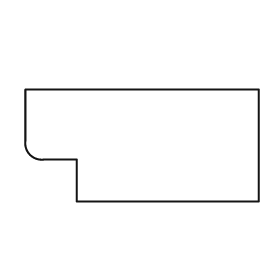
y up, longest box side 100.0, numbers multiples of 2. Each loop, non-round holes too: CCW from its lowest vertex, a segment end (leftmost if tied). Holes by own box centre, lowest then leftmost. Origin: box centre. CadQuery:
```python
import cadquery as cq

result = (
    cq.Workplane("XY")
    .moveTo(-28.0, -24.0)
    .lineTo(50.0, -24.0)
    .lineTo(50.0, 24.0)
    .lineTo(-50.0, 24.0)
    .lineTo(-50.0, 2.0)
    .threePointArc((-48.0, -4.0), (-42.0, -6.0))
    .lineTo(-28.0, -6.0)
    .close()
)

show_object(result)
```